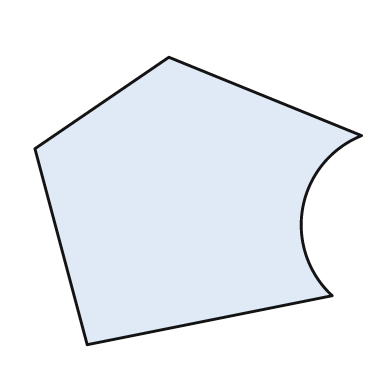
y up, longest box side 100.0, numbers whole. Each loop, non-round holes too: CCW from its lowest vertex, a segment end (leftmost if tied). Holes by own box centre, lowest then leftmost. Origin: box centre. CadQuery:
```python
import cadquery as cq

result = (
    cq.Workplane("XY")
    .moveTo(-34.0, -44.0)
    .lineTo(41.0, -29.0)
    .threePointArc((32.0, -2.0), (50.0, 20.0))
    .lineTo(-9.0, 44.0)
    .lineTo(-50.0, 16.0)
    .close()
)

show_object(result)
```